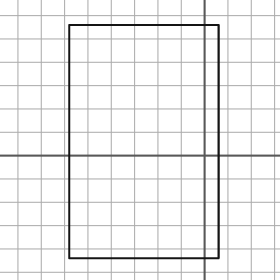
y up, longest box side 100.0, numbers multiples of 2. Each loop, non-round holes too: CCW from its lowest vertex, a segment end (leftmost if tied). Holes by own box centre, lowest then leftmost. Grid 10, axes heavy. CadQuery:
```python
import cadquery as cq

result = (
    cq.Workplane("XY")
    .moveTo(-58.0, -44.0)
    .lineTo(6.0, -44.0)
    .lineTo(6.0, 56.0)
    .lineTo(-58.0, 56.0)
    .close()
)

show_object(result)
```